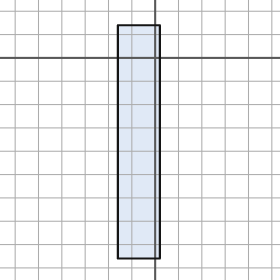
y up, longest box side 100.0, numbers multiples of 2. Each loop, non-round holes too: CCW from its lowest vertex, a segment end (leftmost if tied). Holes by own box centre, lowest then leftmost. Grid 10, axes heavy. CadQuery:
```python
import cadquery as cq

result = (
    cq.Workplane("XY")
    .moveTo(-16.0, -86.0)
    .lineTo(2.0, -86.0)
    .lineTo(2.0, 14.0)
    .lineTo(-16.0, 14.0)
    .close()
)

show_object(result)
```